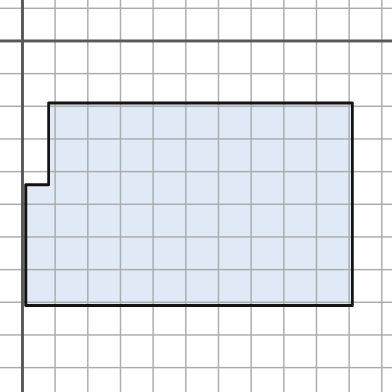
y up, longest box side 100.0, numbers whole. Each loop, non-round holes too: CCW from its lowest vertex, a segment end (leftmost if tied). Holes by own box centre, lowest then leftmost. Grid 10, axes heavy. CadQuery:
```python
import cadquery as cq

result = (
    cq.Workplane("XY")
    .moveTo(1.0, -81.0)
    .lineTo(101.0, -81.0)
    .lineTo(101.0, -19.0)
    .lineTo(8.0, -19.0)
    .lineTo(8.0, -44.0)
    .lineTo(1.0, -44.0)
    .close()
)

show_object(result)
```